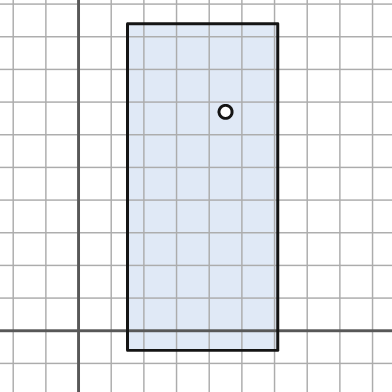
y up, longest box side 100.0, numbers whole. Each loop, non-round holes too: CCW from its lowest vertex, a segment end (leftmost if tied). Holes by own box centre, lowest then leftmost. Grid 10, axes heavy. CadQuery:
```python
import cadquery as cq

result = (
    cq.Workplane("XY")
    .moveTo(15.0, -6.0)
    .lineTo(61.0, -6.0)
    .lineTo(61.0, 94.0)
    .lineTo(15.0, 94.0)
    .close()
    .moveTo(45.0, 67.0)
    .circle(2.0)
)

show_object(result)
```